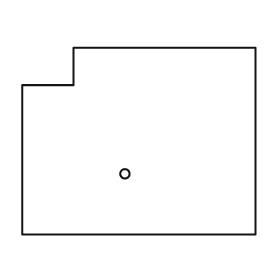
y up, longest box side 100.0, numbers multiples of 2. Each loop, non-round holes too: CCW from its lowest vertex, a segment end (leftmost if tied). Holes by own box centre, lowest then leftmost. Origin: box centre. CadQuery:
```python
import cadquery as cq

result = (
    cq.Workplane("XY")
    .moveTo(-50.0, -40.0)
    .lineTo(50.0, -40.0)
    .lineTo(50.0, 40.0)
    .lineTo(-28.0, 40.0)
    .lineTo(-28.0, 24.0)
    .lineTo(-50.0, 24.0)
    .close()
    .moveTo(-6.0, -14.0)
    .circle(2.0)
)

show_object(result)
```